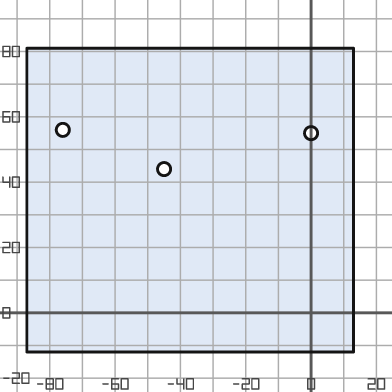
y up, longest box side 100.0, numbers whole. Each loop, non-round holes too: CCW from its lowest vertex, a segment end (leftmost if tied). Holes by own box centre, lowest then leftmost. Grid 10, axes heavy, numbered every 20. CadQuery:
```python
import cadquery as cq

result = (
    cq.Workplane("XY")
    .moveTo(-87.0, -12.0)
    .lineTo(13.0, -12.0)
    .lineTo(13.0, 81.0)
    .lineTo(-87.0, 81.0)
    .close()
    .moveTo(-45.0, 44.0)
    .circle(2.0)
    .moveTo(0.0, 55.0)
    .circle(2.0)
    .moveTo(-76.0, 56.0)
    .circle(2.0)
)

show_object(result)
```